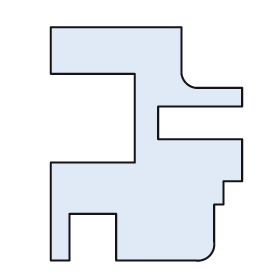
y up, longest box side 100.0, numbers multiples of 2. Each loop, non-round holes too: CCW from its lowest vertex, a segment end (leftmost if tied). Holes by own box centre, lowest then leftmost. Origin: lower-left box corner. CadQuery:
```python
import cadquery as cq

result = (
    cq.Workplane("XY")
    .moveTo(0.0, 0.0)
    .lineTo(8.0, 0.0)
    .lineTo(8.0, 20.0)
    .lineTo(28.0, 20.0)
    .lineTo(28.0, 0.0)
    .lineTo(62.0, 0.0)
    .threePointArc((68.0, 2.0), (70.0, 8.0))
    .lineTo(70.0, 24.0)
    .lineTo(74.0, 24.0)
    .lineTo(74.0, 34.0)
    .lineTo(82.0, 34.0)
    .lineTo(82.0, 52.0)
    .lineTo(46.0, 52.0)
    .lineTo(46.0, 66.0)
    .lineTo(82.0, 66.0)
    .lineTo(82.0, 74.0)
    .lineTo(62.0, 74.0)
    .threePointArc((58.0, 76.0), (56.0, 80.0))
    .lineTo(56.0, 100.0)
    .lineTo(0.0, 100.0)
    .lineTo(0.0, 80.0)
    .lineTo(36.0, 80.0)
    .lineTo(36.0, 42.0)
    .lineTo(0.0, 42.0)
    .close()
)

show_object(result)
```